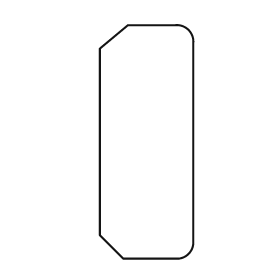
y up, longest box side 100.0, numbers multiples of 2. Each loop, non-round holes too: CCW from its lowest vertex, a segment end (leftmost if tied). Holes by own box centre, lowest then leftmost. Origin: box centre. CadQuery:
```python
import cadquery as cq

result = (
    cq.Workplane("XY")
    .moveTo(-10.0, -50.0)
    .lineTo(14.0, -50.0)
    .threePointArc((18.0, -48.0), (20.0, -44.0))
    .lineTo(20.0, 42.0)
    .threePointArc((18.0, 48.0), (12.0, 50.0))
    .lineTo(-8.0, 50.0)
    .lineTo(-20.0, 40.0)
    .lineTo(-20.0, -40.0)
    .close()
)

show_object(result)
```